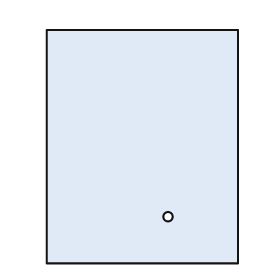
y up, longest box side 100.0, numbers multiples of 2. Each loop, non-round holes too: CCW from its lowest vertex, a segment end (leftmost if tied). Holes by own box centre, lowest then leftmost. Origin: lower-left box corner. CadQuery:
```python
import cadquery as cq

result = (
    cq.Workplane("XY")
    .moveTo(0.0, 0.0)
    .lineTo(82.0, 0.0)
    .lineTo(82.0, 100.0)
    .lineTo(0.0, 100.0)
    .close()
    .moveTo(52.0, 20.0)
    .circle(2.0)
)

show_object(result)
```